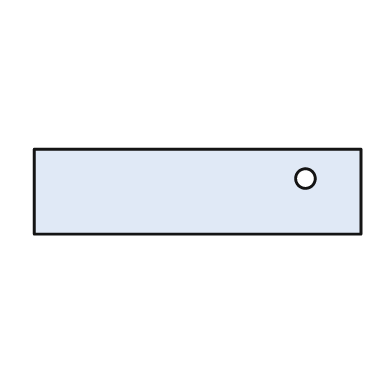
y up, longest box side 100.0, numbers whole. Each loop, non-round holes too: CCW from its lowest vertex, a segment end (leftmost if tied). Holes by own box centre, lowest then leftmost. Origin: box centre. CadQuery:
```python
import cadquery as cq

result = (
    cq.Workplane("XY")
    .moveTo(-50.0, -13.0)
    .lineTo(50.0, -13.0)
    .lineTo(50.0, 13.0)
    .lineTo(-50.0, 13.0)
    .close()
    .moveTo(33.0, 4.0)
    .circle(3.0)
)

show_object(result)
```